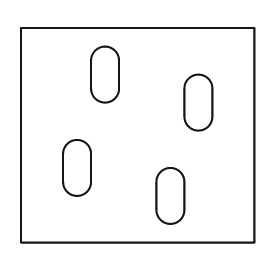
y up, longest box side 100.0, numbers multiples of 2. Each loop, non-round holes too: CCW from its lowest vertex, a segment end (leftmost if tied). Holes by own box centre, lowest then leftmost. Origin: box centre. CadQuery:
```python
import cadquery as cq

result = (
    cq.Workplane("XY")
    .moveTo(-50.0, -46.0)
    .lineTo(50.0, -46.0)
    .lineTo(50.0, 46.0)
    .lineTo(-50.0, 46.0)
    .close()
    .moveTo(8.0, -32.0)
    .threePointArc((14.0, -38.0), (20.0, -32.0))
    .lineTo(20.0, -20.0)
    .threePointArc((14.0, -14.0), (8.0, -20.0))
    .close()
    .moveTo(-32.0, -20.0)
    .threePointArc((-26.0, -26.0), (-20.0, -20.0))
    .lineTo(-20.0, -8.0)
    .threePointArc((-26.0, -2.0), (-32.0, -8.0))
    .close()
    .moveTo(20.0, 8.0)
    .threePointArc((26.0, 2.0), (32.0, 8.0))
    .lineTo(32.0, 20.0)
    .threePointArc((26.0, 26.0), (20.0, 20.0))
    .close()
    .moveTo(-20.0, 20.0)
    .threePointArc((-14.0, 14.0), (-8.0, 20.0))
    .lineTo(-8.0, 32.0)
    .threePointArc((-14.0, 38.0), (-20.0, 32.0))
    .close()
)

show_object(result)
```